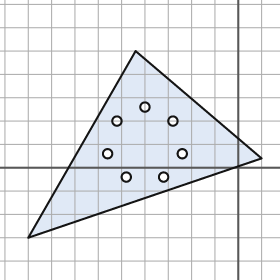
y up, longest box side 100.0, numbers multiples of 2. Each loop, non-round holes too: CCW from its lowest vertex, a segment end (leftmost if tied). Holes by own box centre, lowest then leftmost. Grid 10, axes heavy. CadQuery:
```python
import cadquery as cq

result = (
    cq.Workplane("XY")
    .moveTo(-90.0, -30.0)
    .lineTo(10.0, 4.0)
    .lineTo(-44.0, 50.0)
    .close()
    .moveTo(-48.0, -4.0)
    .circle(2.0)
    .moveTo(-32.0, -4.0)
    .circle(2.0)
    .moveTo(-56.0, 6.0)
    .circle(2.0)
    .moveTo(-24.0, 6.0)
    .circle(2.0)
    .moveTo(-52.0, 20.0)
    .circle(2.0)
    .moveTo(-28.0, 20.0)
    .circle(2.0)
    .moveTo(-40.0, 26.0)
    .circle(2.0)
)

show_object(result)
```